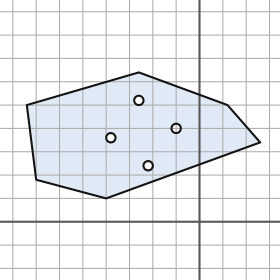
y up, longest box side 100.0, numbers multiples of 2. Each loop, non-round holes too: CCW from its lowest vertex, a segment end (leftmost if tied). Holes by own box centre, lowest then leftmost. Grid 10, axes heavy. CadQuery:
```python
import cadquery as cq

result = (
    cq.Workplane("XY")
    .moveTo(-40.0, 10.0)
    .lineTo(26.0, 34.0)
    .lineTo(12.0, 50.0)
    .lineTo(-26.0, 64.0)
    .lineTo(-74.0, 50.0)
    .lineTo(-70.0, 18.0)
    .close()
    .moveTo(-22.0, 24.0)
    .circle(2.0)
    .moveTo(-38.0, 36.0)
    .circle(2.0)
    .moveTo(-10.0, 40.0)
    .circle(2.0)
    .moveTo(-26.0, 52.0)
    .circle(2.0)
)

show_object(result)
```